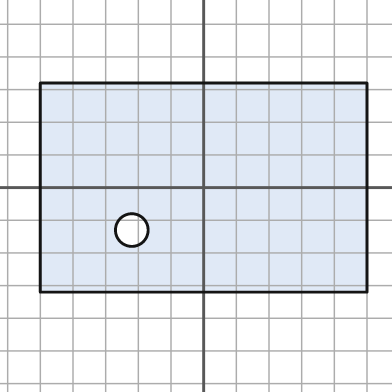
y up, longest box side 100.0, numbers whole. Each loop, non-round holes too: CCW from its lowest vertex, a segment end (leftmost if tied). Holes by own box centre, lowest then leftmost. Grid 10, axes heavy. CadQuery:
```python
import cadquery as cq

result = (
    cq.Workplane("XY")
    .moveTo(-50.0, -32.0)
    .lineTo(50.0, -32.0)
    .lineTo(50.0, 32.0)
    .lineTo(-50.0, 32.0)
    .close()
    .moveTo(-22.0, -13.0)
    .circle(5.0)
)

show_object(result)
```